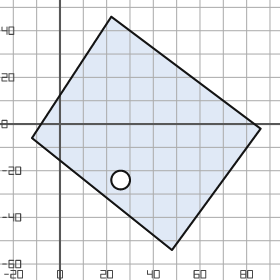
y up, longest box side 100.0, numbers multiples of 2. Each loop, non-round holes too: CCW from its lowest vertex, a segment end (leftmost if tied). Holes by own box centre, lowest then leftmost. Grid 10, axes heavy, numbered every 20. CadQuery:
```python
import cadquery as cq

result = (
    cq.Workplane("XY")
    .moveTo(48.0, -54.0)
    .lineTo(86.0, -2.0)
    .lineTo(22.0, 46.0)
    .lineTo(-12.0, -6.0)
    .close()
    .moveTo(26.0, -24.0)
    .circle(4.0)
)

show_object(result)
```